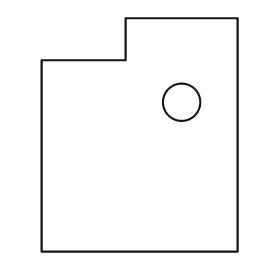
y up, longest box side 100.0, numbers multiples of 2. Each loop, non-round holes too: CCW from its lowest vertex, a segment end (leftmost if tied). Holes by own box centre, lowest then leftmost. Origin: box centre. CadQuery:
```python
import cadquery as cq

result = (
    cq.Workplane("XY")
    .moveTo(-42.0, -50.0)
    .lineTo(42.0, -50.0)
    .lineTo(42.0, 50.0)
    .lineTo(-6.0, 50.0)
    .lineTo(-6.0, 32.0)
    .lineTo(-42.0, 32.0)
    .close()
    .moveTo(18.0, 14.0)
    .circle(8.0)
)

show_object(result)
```